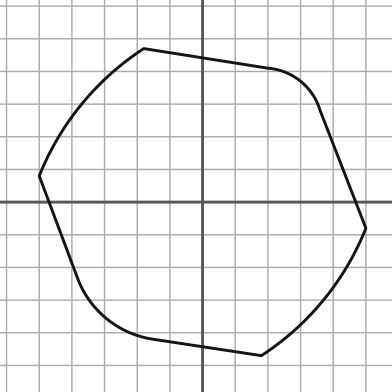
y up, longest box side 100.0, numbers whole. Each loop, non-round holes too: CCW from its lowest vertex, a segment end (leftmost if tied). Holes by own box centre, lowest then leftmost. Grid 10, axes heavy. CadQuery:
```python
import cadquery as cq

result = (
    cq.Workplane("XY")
    .moveTo(18.0, -47.0)
    .threePointArc((37.0, -30.0), (50.0, -8.0))
    .lineTo(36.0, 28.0)
    .threePointArc((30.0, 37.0), (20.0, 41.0))
    .lineTo(-18.0, 47.0)
    .threePointArc((-37.0, 30.0), (-50.0, 8.0))
    .lineTo(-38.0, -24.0)
    .threePointArc((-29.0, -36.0), (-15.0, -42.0))
    .close()
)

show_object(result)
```